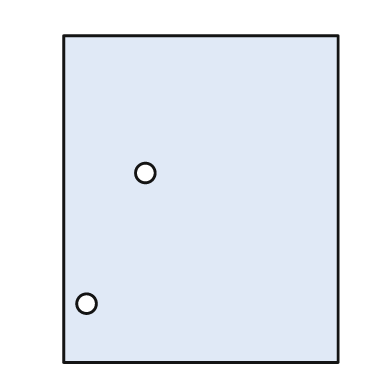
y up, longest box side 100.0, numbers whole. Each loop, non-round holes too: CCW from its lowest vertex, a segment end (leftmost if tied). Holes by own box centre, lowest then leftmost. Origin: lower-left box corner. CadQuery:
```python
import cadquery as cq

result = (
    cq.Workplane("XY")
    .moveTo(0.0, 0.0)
    .lineTo(84.0, 0.0)
    .lineTo(84.0, 100.0)
    .lineTo(0.0, 100.0)
    .close()
    .moveTo(7.0, 18.0)
    .circle(3.0)
    .moveTo(25.0, 58.0)
    .circle(3.0)
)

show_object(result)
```